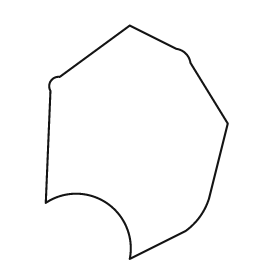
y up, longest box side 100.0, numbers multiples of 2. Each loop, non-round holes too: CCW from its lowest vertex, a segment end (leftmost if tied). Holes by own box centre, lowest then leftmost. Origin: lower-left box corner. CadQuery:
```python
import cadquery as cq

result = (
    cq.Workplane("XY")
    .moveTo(36.0, 0.0)
    .lineTo(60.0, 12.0)
    .threePointArc((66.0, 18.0), (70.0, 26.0))
    .lineTo(78.0, 58.0)
    .lineTo(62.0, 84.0)
    .threePointArc((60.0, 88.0), (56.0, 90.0))
    .lineTo(36.0, 100.0)
    .lineTo(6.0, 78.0)
    .threePointArc((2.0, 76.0), (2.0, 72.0))
    .lineTo(0.0, 24.0)
    .threePointArc((26.0, 24.0), (36.0, 0.0))
    .close()
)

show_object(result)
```